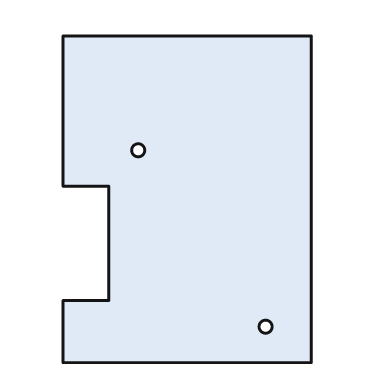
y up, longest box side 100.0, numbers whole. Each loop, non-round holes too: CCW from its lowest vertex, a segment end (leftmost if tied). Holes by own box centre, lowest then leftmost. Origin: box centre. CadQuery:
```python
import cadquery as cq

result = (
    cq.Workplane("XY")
    .moveTo(-38.0, -50.0)
    .lineTo(38.0, -50.0)
    .lineTo(38.0, 50.0)
    .lineTo(-38.0, 50.0)
    .lineTo(-38.0, 4.0)
    .lineTo(-24.0, 4.0)
    .lineTo(-24.0, -31.0)
    .lineTo(-38.0, -31.0)
    .close()
    .moveTo(24.0, -39.0)
    .circle(2.0)
    .moveTo(-15.0, 15.0)
    .circle(2.0)
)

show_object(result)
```